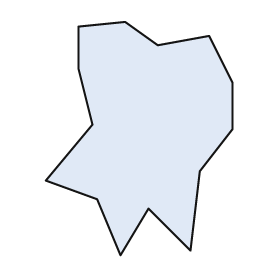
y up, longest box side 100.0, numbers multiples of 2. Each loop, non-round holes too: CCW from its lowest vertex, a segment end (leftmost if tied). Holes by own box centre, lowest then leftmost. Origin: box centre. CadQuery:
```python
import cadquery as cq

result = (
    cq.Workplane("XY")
    .moveTo(-8.0, -50.0)
    .lineTo(4.0, -30.0)
    .lineTo(22.0, -48.0)
    .lineTo(26.0, -14.0)
    .lineTo(40.0, 4.0)
    .lineTo(40.0, 24.0)
    .lineTo(30.0, 44.0)
    .lineTo(8.0, 40.0)
    .lineTo(-6.0, 50.0)
    .lineTo(-26.0, 48.0)
    .lineTo(-26.0, 30.0)
    .lineTo(-20.0, 6.0)
    .lineTo(-40.0, -18.0)
    .lineTo(-18.0, -26.0)
    .close()
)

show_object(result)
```